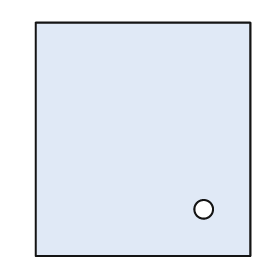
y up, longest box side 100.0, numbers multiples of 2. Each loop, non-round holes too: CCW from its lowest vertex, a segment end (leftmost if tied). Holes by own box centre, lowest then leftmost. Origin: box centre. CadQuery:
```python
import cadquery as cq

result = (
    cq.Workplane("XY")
    .moveTo(-46.0, -50.0)
    .lineTo(46.0, -50.0)
    .lineTo(46.0, 50.0)
    .lineTo(-46.0, 50.0)
    .close()
    .moveTo(26.0, -30.0)
    .circle(4.0)
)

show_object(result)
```